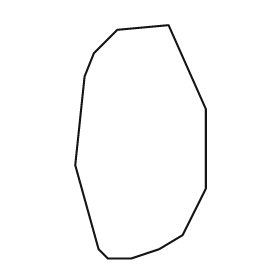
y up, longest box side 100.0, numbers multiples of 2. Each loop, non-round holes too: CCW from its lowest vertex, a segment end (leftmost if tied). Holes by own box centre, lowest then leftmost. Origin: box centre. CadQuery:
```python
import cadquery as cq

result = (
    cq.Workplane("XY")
    .moveTo(-14.0, -50.0)
    .lineTo(-4.0, -50.0)
    .lineTo(8.0, -46.0)
    .lineTo(18.0, -40.0)
    .lineTo(28.0, -20.0)
    .lineTo(28.0, 14.0)
    .lineTo(12.0, 50.0)
    .lineTo(-10.0, 48.0)
    .lineTo(-20.0, 38.0)
    .lineTo(-24.0, 28.0)
    .lineTo(-28.0, -10.0)
    .lineTo(-18.0, -46.0)
    .close()
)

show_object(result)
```